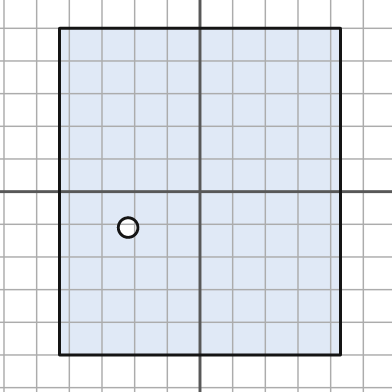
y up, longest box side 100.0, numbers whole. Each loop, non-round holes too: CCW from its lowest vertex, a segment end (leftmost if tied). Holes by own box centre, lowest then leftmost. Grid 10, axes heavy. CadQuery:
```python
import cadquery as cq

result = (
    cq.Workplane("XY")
    .moveTo(-43.0, -50.0)
    .lineTo(43.0, -50.0)
    .lineTo(43.0, 50.0)
    .lineTo(-43.0, 50.0)
    .close()
    .moveTo(-22.0, -11.0)
    .circle(3.0)
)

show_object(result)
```